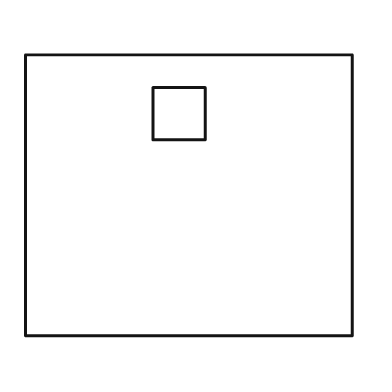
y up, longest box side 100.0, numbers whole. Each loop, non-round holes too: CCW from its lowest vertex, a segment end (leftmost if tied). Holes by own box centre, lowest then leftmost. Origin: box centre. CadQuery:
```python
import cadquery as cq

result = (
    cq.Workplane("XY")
    .moveTo(-50.0, -43.0)
    .lineTo(50.0, -43.0)
    .lineTo(50.0, 43.0)
    .lineTo(-50.0, 43.0)
    .close()
    .moveTo(-11.0, 17.0)
    .lineTo(5.0, 17.0)
    .lineTo(5.0, 33.0)
    .lineTo(-11.0, 33.0)
    .close()
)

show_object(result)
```